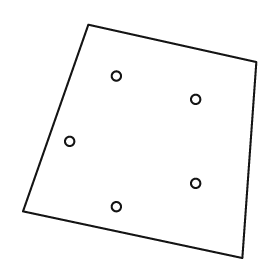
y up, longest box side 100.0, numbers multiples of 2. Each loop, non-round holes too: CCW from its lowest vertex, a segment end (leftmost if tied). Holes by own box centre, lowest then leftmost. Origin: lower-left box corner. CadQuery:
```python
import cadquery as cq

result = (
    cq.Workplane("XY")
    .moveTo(94.0, 0.0)
    .lineTo(100.0, 84.0)
    .lineTo(28.0, 100.0)
    .lineTo(0.0, 20.0)
    .close()
    .moveTo(40.0, 22.0)
    .circle(2.0)
    .moveTo(74.0, 32.0)
    .circle(2.0)
    .moveTo(20.0, 50.0)
    .circle(2.0)
    .moveTo(74.0, 68.0)
    .circle(2.0)
    .moveTo(40.0, 78.0)
    .circle(2.0)
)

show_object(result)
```